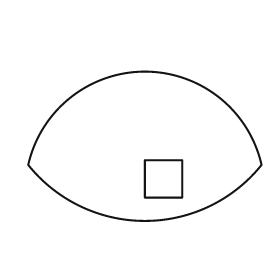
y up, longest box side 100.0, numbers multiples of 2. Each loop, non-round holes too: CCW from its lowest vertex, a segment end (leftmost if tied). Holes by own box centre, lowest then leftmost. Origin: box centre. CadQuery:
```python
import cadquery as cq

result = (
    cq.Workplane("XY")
    .moveTo(-50.0, -8.0)
    .threePointArc((0.0, -32.0), (50.0, -8.0))
    .threePointArc((0.0, 32.0), (-50.0, -8.0))
    .close()
    .moveTo(0.0, -22.0)
    .lineTo(16.0, -22.0)
    .lineTo(16.0, -6.0)
    .lineTo(0.0, -6.0)
    .close()
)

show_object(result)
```